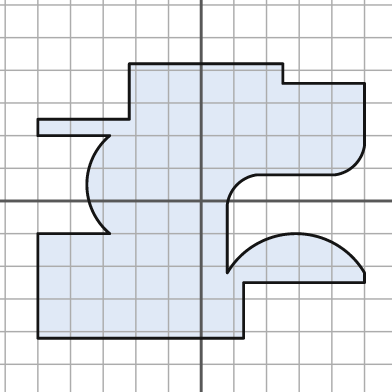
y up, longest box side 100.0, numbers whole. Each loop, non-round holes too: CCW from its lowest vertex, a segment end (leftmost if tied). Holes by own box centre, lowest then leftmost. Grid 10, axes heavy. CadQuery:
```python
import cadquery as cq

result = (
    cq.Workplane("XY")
    .moveTo(-50.0, -42.0)
    .lineTo(13.0, -42.0)
    .lineTo(13.0, -25.0)
    .lineTo(50.0, -25.0)
    .lineTo(50.0, -22.0)
    .threePointArc((29.0, -10.0), (8.0, -22.0))
    .lineTo(8.0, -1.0)
    .threePointArc((11.0, 5.0), (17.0, 8.0))
    .lineTo(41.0, 8.0)
    .threePointArc((47.0, 11.0), (50.0, 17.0))
    .lineTo(50.0, 36.0)
    .lineTo(25.0, 36.0)
    .lineTo(25.0, 42.0)
    .lineTo(-22.0, 42.0)
    .lineTo(-22.0, 25.0)
    .lineTo(-50.0, 25.0)
    .lineTo(-50.0, 20.0)
    .lineTo(-28.0, 20.0)
    .threePointArc((-35.0, 5.0), (-28.0, -10.0))
    .lineTo(-50.0, -10.0)
    .close()
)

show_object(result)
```